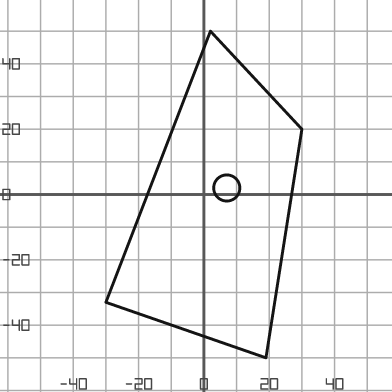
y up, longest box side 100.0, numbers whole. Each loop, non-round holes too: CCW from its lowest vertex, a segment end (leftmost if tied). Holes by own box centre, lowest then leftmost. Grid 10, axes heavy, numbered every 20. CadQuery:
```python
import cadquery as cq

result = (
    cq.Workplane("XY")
    .moveTo(19.0, -50.0)
    .lineTo(30.0, 20.0)
    .lineTo(2.0, 50.0)
    .lineTo(-30.0, -33.0)
    .close()
    .moveTo(7.0, 2.0)
    .circle(4.0)
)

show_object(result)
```